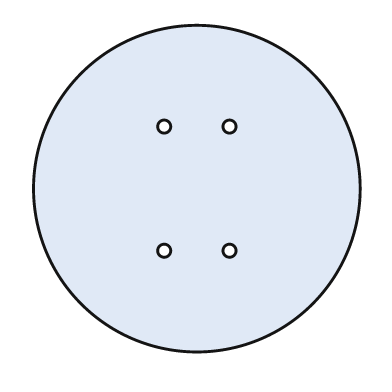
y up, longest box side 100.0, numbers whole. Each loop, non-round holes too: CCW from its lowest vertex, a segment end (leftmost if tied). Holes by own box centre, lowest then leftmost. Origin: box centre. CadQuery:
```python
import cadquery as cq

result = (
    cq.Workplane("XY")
    .moveTo(0.0, 0.0)
    .circle(50.0)
    .moveTo(-10.0, -19.0)
    .circle(2.0)
    .moveTo(10.0, -19.0)
    .circle(2.0)
    .moveTo(-10.0, 19.0)
    .circle(2.0)
    .moveTo(10.0, 19.0)
    .circle(2.0)
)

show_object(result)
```